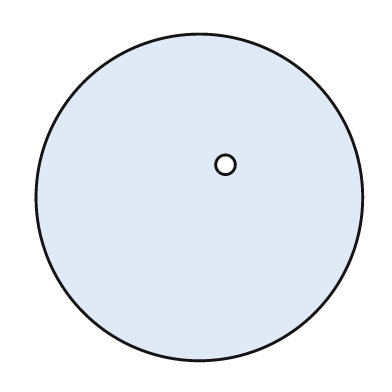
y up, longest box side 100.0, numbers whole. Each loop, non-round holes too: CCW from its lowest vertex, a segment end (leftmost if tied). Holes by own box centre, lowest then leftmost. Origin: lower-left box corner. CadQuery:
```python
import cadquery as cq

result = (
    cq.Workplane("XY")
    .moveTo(50.0, 50.0)
    .circle(50.0)
    .moveTo(58.0, 60.0)
    .circle(3.0)
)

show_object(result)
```